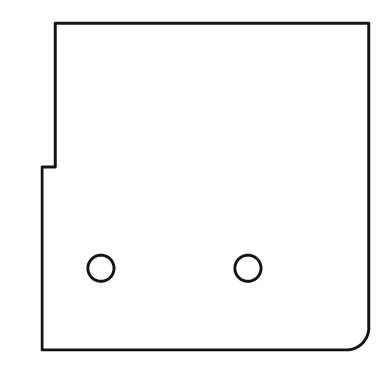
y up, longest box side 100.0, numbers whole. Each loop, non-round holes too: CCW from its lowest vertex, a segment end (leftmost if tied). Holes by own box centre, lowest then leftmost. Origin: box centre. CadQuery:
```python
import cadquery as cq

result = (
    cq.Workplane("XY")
    .moveTo(-50.0, -50.0)
    .lineTo(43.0, -50.0)
    .threePointArc((48.0, -48.0), (50.0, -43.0))
    .lineTo(50.0, 50.0)
    .lineTo(-46.0, 50.0)
    .lineTo(-46.0, 6.0)
    .lineTo(-50.0, 6.0)
    .close()
    .moveTo(-32.0, -25.0)
    .circle(4.0)
    .moveTo(13.0, -25.0)
    .circle(4.0)
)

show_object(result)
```